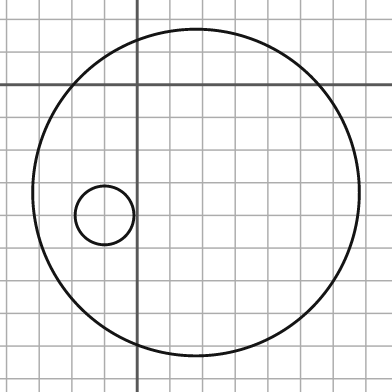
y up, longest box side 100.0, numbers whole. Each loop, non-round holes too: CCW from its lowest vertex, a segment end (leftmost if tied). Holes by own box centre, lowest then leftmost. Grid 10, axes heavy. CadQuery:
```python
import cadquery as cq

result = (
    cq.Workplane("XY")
    .moveTo(18.0, -33.0)
    .circle(50.0)
    .moveTo(-10.0, -40.0)
    .circle(9.0)
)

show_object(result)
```